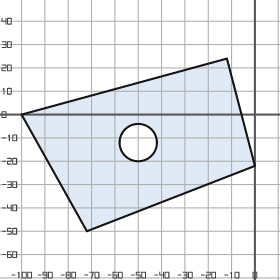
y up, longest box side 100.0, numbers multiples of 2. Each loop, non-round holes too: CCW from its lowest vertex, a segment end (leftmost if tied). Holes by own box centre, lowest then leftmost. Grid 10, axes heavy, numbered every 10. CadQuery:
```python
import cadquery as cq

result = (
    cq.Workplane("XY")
    .moveTo(-72.0, -50.0)
    .lineTo(0.0, -22.0)
    .lineTo(-12.0, 24.0)
    .lineTo(-100.0, 0.0)
    .close()
    .moveTo(-50.0, -12.0)
    .circle(8.0)
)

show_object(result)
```